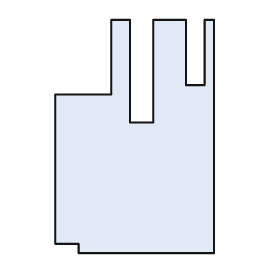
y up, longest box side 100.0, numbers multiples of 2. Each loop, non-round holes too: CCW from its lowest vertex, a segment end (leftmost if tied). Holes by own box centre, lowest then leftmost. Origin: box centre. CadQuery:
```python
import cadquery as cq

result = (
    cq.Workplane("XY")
    .moveTo(-24.0, -50.0)
    .lineTo(34.0, -50.0)
    .lineTo(34.0, 50.0)
    .lineTo(30.0, 50.0)
    .lineTo(30.0, 22.0)
    .lineTo(22.0, 22.0)
    .lineTo(22.0, 50.0)
    .lineTo(8.0, 50.0)
    .lineTo(8.0, 6.0)
    .lineTo(-2.0, 6.0)
    .lineTo(-2.0, 50.0)
    .lineTo(-10.0, 50.0)
    .lineTo(-10.0, 18.0)
    .lineTo(-34.0, 18.0)
    .lineTo(-34.0, -46.0)
    .lineTo(-24.0, -46.0)
    .close()
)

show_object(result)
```